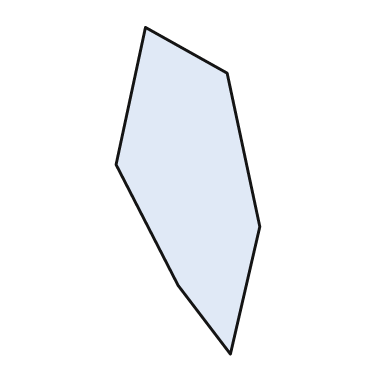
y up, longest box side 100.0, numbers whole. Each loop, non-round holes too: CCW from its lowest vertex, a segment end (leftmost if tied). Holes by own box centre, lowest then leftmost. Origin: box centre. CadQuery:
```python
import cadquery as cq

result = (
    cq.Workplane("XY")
    .moveTo(13.0, -50.0)
    .lineTo(22.0, -11.0)
    .lineTo(12.0, 36.0)
    .lineTo(-13.0, 50.0)
    .lineTo(-22.0, 8.0)
    .lineTo(-3.0, -29.0)
    .close()
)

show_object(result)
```